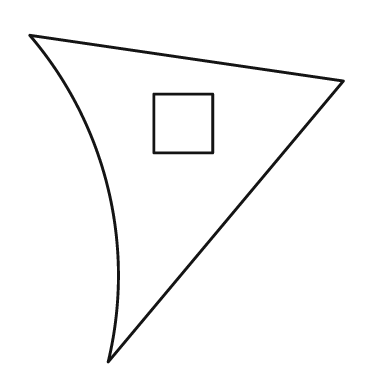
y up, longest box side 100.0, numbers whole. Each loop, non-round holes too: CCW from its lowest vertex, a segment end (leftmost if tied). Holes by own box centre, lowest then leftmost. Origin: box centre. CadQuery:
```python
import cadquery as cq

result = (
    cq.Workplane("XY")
    .moveTo(-24.0, -50.0)
    .lineTo(48.0, 36.0)
    .lineTo(-48.0, 50.0)
    .threePointArc((-24.0, 3.0), (-24.0, -50.0))
    .close()
    .moveTo(-10.0, 14.0)
    .lineTo(8.0, 14.0)
    .lineTo(8.0, 32.0)
    .lineTo(-10.0, 32.0)
    .close()
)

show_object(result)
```